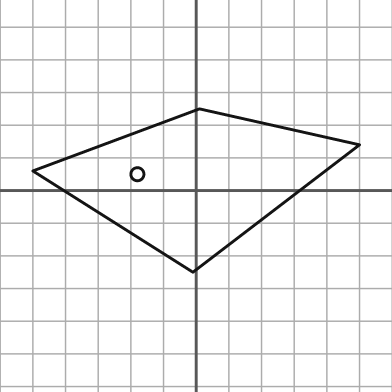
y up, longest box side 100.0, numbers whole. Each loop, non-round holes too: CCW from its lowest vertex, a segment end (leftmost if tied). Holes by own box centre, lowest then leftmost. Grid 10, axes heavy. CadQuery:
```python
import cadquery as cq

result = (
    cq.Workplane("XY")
    .moveTo(-1.0, -25.0)
    .lineTo(50.0, 14.0)
    .lineTo(1.0, 25.0)
    .lineTo(-50.0, 6.0)
    .close()
    .moveTo(-18.0, 5.0)
    .circle(2.0)
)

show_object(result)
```